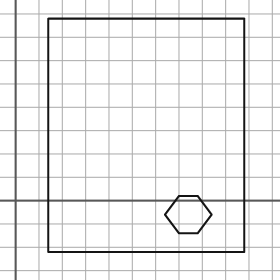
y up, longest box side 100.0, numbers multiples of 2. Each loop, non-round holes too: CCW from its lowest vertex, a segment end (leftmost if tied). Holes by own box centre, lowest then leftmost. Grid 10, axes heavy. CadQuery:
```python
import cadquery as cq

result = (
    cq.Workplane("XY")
    .moveTo(14.0, -22.0)
    .lineTo(98.0, -22.0)
    .lineTo(98.0, 78.0)
    .lineTo(14.0, 78.0)
    .close()
    .moveTo(70.0, -14.0)
    .lineTo(78.0, -14.0)
    .lineTo(84.0, -6.0)
    .lineTo(78.0, 2.0)
    .lineTo(70.0, 2.0)
    .lineTo(64.0, -6.0)
    .close()
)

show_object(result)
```